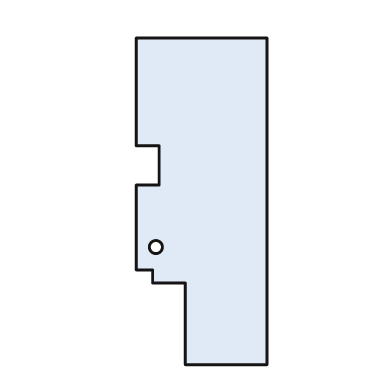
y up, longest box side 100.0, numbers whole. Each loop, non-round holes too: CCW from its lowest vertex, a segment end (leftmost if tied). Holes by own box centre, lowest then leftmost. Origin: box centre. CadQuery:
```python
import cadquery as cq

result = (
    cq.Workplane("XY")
    .moveTo(-5.0, -50.0)
    .lineTo(20.0, -50.0)
    .lineTo(20.0, 50.0)
    .lineTo(-20.0, 50.0)
    .lineTo(-20.0, 17.0)
    .lineTo(-13.0, 17.0)
    .lineTo(-13.0, 5.0)
    .lineTo(-20.0, 5.0)
    .lineTo(-20.0, -21.0)
    .lineTo(-15.0, -21.0)
    .lineTo(-15.0, -25.0)
    .lineTo(-5.0, -25.0)
    .close()
    .moveTo(-14.0, -14.0)
    .circle(2.0)
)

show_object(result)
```